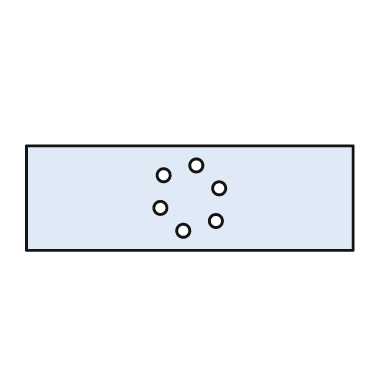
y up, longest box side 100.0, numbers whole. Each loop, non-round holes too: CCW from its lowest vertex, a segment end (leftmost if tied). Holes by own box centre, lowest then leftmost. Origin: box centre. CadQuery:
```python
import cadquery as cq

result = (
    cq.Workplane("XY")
    .moveTo(-50.0, -16.0)
    .lineTo(50.0, -16.0)
    .lineTo(50.0, 16.0)
    .lineTo(-50.0, 16.0)
    .close()
    .moveTo(-2.0, -10.0)
    .circle(2.0)
    .moveTo(8.0, -7.0)
    .circle(2.0)
    .moveTo(-9.0, -3.0)
    .circle(2.0)
    .moveTo(9.0, 3.0)
    .circle(2.0)
    .moveTo(-8.0, 7.0)
    .circle(2.0)
    .moveTo(2.0, 10.0)
    .circle(2.0)
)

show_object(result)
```